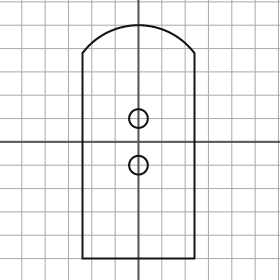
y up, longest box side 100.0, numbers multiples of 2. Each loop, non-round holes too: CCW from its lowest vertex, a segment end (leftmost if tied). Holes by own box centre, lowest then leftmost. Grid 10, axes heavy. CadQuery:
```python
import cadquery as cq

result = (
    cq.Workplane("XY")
    .moveTo(-24.0, -50.0)
    .lineTo(24.0, -50.0)
    .lineTo(24.0, 38.0)
    .threePointArc((0.0, 50.0), (-24.0, 38.0))
    .close()
    .moveTo(0.0, -10.0)
    .circle(4.0)
    .moveTo(0.0, 10.0)
    .circle(4.0)
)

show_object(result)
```